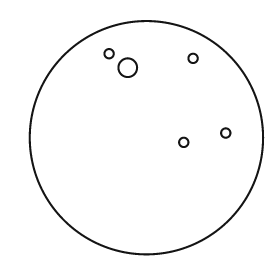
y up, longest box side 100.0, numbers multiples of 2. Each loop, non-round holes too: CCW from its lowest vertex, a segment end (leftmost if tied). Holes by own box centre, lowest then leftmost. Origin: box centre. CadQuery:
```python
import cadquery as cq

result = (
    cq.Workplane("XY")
    .moveTo(0.0, 0.0)
    .circle(50.0)
    .moveTo(16.0, -2.0)
    .circle(2.0)
    .moveTo(34.0, 2.0)
    .circle(2.0)
    .moveTo(-8.0, 30.0)
    .circle(4.0)
    .moveTo(20.0, 34.0)
    .circle(2.0)
    .moveTo(-16.0, 36.0)
    .circle(2.0)
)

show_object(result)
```